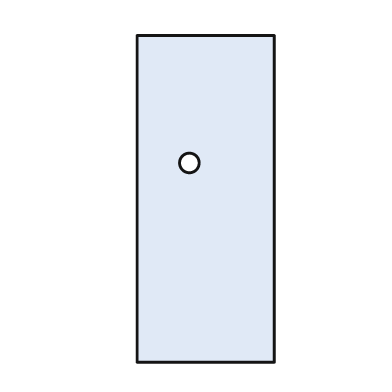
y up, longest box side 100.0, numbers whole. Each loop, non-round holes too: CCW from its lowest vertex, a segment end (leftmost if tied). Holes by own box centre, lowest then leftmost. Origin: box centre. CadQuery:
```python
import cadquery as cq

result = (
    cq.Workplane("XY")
    .moveTo(-21.0, -50.0)
    .lineTo(21.0, -50.0)
    .lineTo(21.0, 50.0)
    .lineTo(-21.0, 50.0)
    .close()
    .moveTo(-5.0, 11.0)
    .circle(3.0)
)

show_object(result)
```